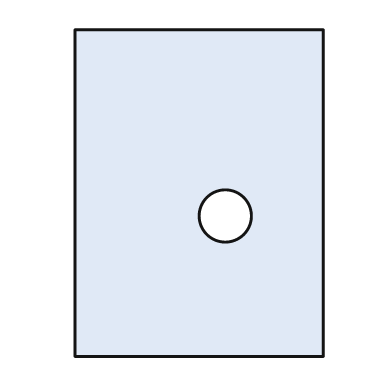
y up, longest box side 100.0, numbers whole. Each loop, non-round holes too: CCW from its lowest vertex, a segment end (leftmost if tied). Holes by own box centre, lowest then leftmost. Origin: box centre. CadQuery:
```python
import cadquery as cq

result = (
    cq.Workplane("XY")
    .moveTo(-38.0, -50.0)
    .lineTo(38.0, -50.0)
    .lineTo(38.0, 50.0)
    .lineTo(-38.0, 50.0)
    .close()
    .moveTo(8.0, -7.0)
    .circle(8.0)
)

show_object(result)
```